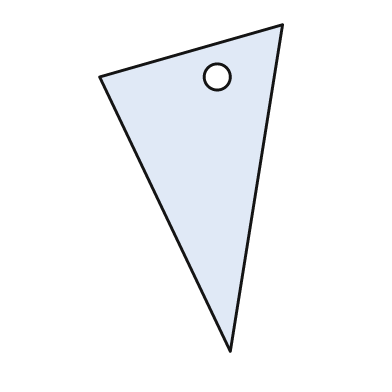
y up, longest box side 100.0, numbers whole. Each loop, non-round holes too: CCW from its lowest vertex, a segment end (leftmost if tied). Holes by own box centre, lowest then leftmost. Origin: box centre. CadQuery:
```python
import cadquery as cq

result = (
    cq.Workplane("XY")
    .moveTo(12.0, -50.0)
    .lineTo(28.0, 50.0)
    .lineTo(-28.0, 34.0)
    .close()
    .moveTo(8.0, 34.0)
    .circle(4.0)
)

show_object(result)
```